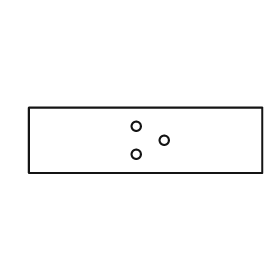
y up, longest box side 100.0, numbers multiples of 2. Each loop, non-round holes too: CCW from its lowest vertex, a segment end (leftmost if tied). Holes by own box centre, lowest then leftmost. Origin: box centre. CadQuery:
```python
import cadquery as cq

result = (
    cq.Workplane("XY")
    .moveTo(-50.0, -14.0)
    .lineTo(50.0, -14.0)
    .lineTo(50.0, 14.0)
    .lineTo(-50.0, 14.0)
    .close()
    .moveTo(-4.0, -6.0)
    .circle(2.0)
    .moveTo(8.0, 0.0)
    .circle(2.0)
    .moveTo(-4.0, 6.0)
    .circle(2.0)
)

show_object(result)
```